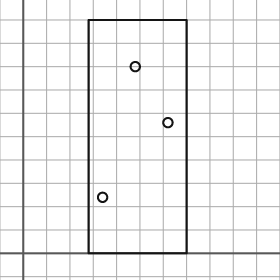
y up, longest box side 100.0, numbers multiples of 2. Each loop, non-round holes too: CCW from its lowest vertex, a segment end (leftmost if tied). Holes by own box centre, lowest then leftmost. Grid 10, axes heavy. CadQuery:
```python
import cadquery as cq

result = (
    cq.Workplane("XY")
    .moveTo(28.0, 0.0)
    .lineTo(70.0, 0.0)
    .lineTo(70.0, 100.0)
    .lineTo(28.0, 100.0)
    .close()
    .moveTo(34.0, 24.0)
    .circle(2.0)
    .moveTo(62.0, 56.0)
    .circle(2.0)
    .moveTo(48.0, 80.0)
    .circle(2.0)
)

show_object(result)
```